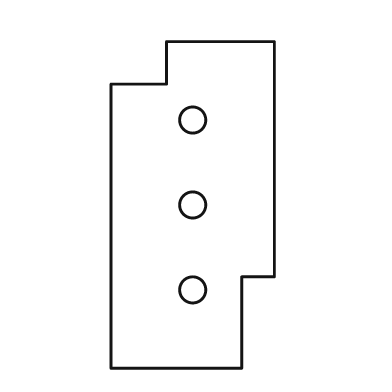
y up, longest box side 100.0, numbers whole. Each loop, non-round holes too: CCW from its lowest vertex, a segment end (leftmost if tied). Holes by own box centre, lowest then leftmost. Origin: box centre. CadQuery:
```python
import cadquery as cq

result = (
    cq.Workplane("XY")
    .moveTo(-25.0, -50.0)
    .lineTo(15.0, -50.0)
    .lineTo(15.0, -22.0)
    .lineTo(25.0, -22.0)
    .lineTo(25.0, 50.0)
    .lineTo(-8.0, 50.0)
    .lineTo(-8.0, 37.0)
    .lineTo(-25.0, 37.0)
    .close()
    .moveTo(0.0, -26.0)
    .circle(4.0)
    .moveTo(0.0, 0.0)
    .circle(4.0)
    .moveTo(0.0, 26.0)
    .circle(4.0)
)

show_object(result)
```